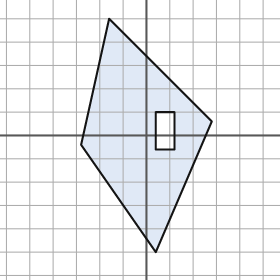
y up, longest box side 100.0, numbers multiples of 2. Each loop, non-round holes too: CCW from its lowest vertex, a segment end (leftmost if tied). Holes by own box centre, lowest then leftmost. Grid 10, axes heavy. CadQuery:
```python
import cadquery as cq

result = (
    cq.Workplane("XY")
    .moveTo(4.0, -50.0)
    .lineTo(28.0, 6.0)
    .lineTo(-16.0, 50.0)
    .lineTo(-28.0, -4.0)
    .close()
    .moveTo(4.0, -6.0)
    .lineTo(12.0, -6.0)
    .lineTo(12.0, 10.0)
    .lineTo(4.0, 10.0)
    .close()
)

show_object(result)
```